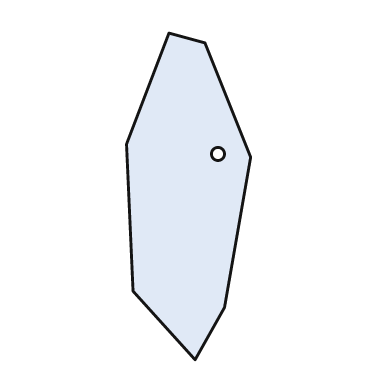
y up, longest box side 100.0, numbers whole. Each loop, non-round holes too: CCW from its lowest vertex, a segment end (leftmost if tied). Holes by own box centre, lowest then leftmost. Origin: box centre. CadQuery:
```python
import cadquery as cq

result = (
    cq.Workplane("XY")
    .moveTo(2.0, -50.0)
    .lineTo(11.0, -34.0)
    .lineTo(19.0, 12.0)
    .lineTo(5.0, 47.0)
    .lineTo(-6.0, 50.0)
    .lineTo(-19.0, 16.0)
    .lineTo(-17.0, -29.0)
    .close()
    .moveTo(9.0, 13.0)
    .circle(2.0)
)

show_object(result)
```